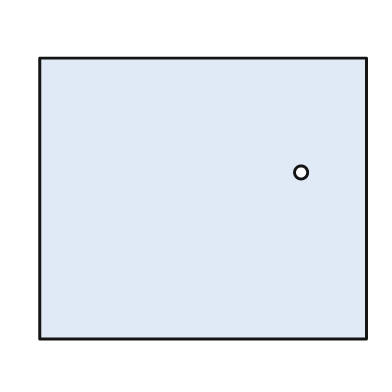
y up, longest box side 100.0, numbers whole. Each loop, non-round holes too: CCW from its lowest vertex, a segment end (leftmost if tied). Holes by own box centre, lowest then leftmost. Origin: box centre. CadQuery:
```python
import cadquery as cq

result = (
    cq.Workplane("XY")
    .moveTo(-50.0, -43.0)
    .lineTo(50.0, -43.0)
    .lineTo(50.0, 43.0)
    .lineTo(-50.0, 43.0)
    .close()
    .moveTo(30.0, 8.0)
    .circle(2.0)
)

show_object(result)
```